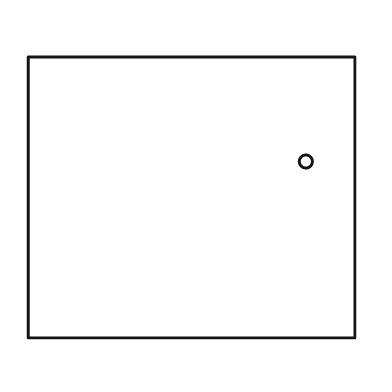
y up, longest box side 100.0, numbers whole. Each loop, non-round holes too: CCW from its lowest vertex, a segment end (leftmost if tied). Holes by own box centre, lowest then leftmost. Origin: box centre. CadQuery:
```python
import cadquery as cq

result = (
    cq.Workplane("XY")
    .moveTo(-50.0, -43.0)
    .lineTo(50.0, -43.0)
    .lineTo(50.0, 43.0)
    .lineTo(-50.0, 43.0)
    .close()
    .moveTo(35.0, 11.0)
    .circle(2.0)
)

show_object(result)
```